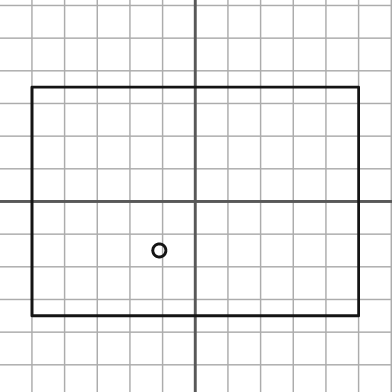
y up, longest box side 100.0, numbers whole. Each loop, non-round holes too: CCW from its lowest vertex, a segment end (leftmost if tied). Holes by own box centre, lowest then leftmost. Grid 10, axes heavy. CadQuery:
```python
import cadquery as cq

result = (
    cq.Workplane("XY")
    .moveTo(-50.0, -35.0)
    .lineTo(50.0, -35.0)
    .lineTo(50.0, 35.0)
    .lineTo(-50.0, 35.0)
    .close()
    .moveTo(-11.0, -15.0)
    .circle(2.0)
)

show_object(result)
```